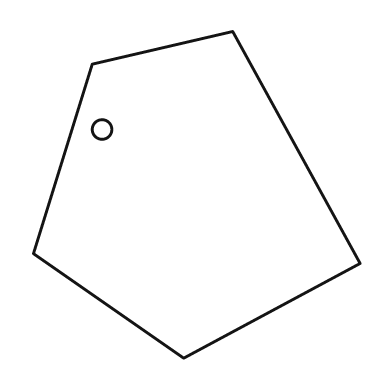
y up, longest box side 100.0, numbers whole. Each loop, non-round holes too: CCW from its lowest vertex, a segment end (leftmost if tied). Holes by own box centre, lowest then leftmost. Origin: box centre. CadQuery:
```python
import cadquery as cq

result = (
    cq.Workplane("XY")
    .moveTo(-4.0, -50.0)
    .lineTo(50.0, -21.0)
    .lineTo(11.0, 50.0)
    .lineTo(-32.0, 40.0)
    .lineTo(-50.0, -18.0)
    .close()
    .moveTo(-29.0, 20.0)
    .circle(3.0)
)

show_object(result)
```